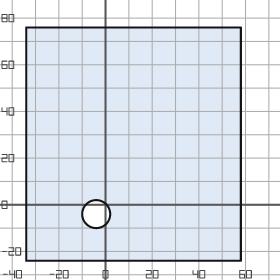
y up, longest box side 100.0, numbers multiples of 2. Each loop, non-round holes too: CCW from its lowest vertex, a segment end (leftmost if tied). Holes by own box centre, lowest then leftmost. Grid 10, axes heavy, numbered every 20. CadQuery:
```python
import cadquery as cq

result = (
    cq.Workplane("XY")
    .moveTo(-34.0, -24.0)
    .lineTo(58.0, -24.0)
    .lineTo(58.0, 76.0)
    .lineTo(-34.0, 76.0)
    .close()
    .moveTo(-4.0, -4.0)
    .circle(6.0)
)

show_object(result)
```